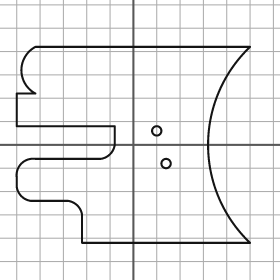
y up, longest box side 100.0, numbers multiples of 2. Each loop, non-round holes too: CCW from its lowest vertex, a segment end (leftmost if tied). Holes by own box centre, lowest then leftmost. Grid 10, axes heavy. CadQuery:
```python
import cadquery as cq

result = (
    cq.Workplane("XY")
    .moveTo(-22.0, -42.0)
    .lineTo(50.0, -42.0)
    .threePointArc((32.0, 0.0), (50.0, 42.0))
    .lineTo(-42.0, 42.0)
    .threePointArc((-48.0, 32.0), (-42.0, 22.0))
    .lineTo(-50.0, 22.0)
    .lineTo(-50.0, 8.0)
    .lineTo(-8.0, 8.0)
    .lineTo(-8.0, 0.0)
    .threePointArc((-10.0, -4.0), (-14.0, -6.0))
    .lineTo(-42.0, -6.0)
    .threePointArc((-48.0, -8.0), (-50.0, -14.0))
    .lineTo(-50.0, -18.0)
    .threePointArc((-48.0, -22.0), (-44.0, -24.0))
    .lineTo(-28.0, -24.0)
    .threePointArc((-24.0, -26.0), (-22.0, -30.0))
    .close()
    .moveTo(14.0, -8.0)
    .circle(2.0)
    .moveTo(10.0, 6.0)
    .circle(2.0)
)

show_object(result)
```